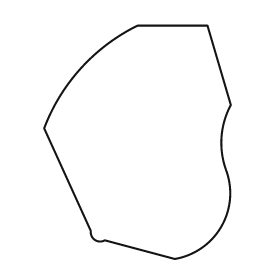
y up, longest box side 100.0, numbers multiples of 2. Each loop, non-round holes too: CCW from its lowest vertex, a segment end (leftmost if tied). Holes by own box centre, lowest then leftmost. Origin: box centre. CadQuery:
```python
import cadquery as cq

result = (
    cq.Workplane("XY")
    .moveTo(16.0, -50.0)
    .threePointArc((36.0, -36.0), (38.0, -12.0))
    .threePointArc((36.0, 2.0), (40.0, 16.0))
    .lineTo(30.0, 50.0)
    .lineTo(0.0, 50.0)
    .threePointArc((-24.0, 32.0), (-40.0, 6.0))
    .lineTo(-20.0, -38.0)
    .threePointArc((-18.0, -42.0), (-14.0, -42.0))
    .close()
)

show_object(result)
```